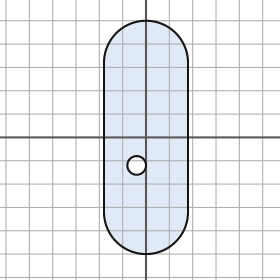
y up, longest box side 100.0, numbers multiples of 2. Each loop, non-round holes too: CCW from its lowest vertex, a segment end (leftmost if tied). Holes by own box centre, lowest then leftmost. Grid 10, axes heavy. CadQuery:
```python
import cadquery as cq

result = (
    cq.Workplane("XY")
    .moveTo(-18.0, -32.0)
    .threePointArc((0.0, -50.0), (18.0, -32.0))
    .lineTo(18.0, 32.0)
    .threePointArc((0.0, 50.0), (-18.0, 32.0))
    .close()
    .moveTo(-4.0, -12.0)
    .circle(4.0)
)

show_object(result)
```